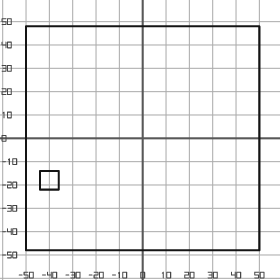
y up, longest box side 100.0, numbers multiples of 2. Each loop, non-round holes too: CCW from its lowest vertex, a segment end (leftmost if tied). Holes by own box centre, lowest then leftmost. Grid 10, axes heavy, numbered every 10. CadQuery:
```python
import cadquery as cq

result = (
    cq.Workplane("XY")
    .moveTo(-50.0, -48.0)
    .lineTo(50.0, -48.0)
    .lineTo(50.0, 48.0)
    .lineTo(-50.0, 48.0)
    .close()
    .moveTo(-44.0, -22.0)
    .lineTo(-36.0, -22.0)
    .lineTo(-36.0, -14.0)
    .lineTo(-44.0, -14.0)
    .close()
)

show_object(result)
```